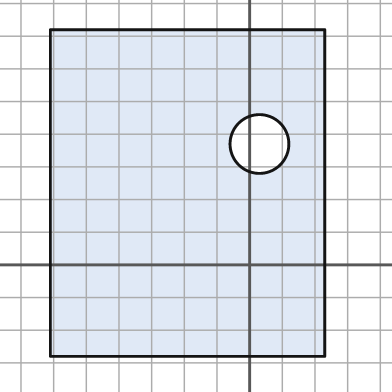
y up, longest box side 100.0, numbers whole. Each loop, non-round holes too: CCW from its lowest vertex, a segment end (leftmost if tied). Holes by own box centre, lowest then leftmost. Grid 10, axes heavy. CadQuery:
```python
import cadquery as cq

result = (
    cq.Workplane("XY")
    .moveTo(-61.0, -28.0)
    .lineTo(23.0, -28.0)
    .lineTo(23.0, 72.0)
    .lineTo(-61.0, 72.0)
    .close()
    .moveTo(3.0, 37.0)
    .circle(9.0)
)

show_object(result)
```